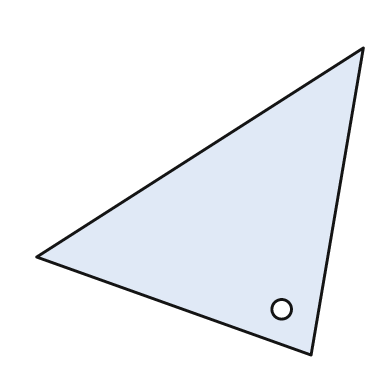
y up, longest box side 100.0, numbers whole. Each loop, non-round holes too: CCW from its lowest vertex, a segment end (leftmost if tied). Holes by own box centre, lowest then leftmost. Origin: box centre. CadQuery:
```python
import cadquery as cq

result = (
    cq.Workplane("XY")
    .moveTo(34.0, -47.0)
    .lineTo(50.0, 47.0)
    .lineTo(-50.0, -17.0)
    .close()
    .moveTo(25.0, -33.0)
    .circle(3.0)
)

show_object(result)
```